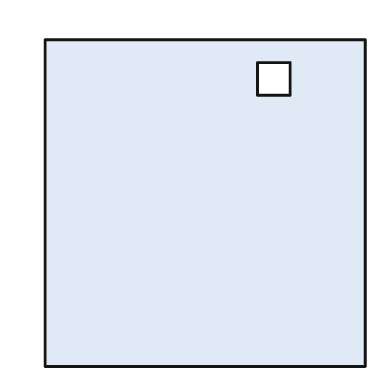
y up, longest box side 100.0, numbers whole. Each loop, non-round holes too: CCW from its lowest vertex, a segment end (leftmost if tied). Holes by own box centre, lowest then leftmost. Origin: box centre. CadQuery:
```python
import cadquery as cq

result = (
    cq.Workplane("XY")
    .moveTo(-49.0, -50.0)
    .lineTo(49.0, -50.0)
    .lineTo(49.0, 50.0)
    .lineTo(-49.0, 50.0)
    .close()
    .moveTo(16.0, 33.0)
    .lineTo(26.0, 33.0)
    .lineTo(26.0, 43.0)
    .lineTo(16.0, 43.0)
    .close()
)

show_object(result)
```